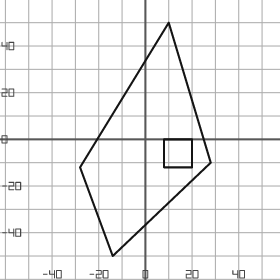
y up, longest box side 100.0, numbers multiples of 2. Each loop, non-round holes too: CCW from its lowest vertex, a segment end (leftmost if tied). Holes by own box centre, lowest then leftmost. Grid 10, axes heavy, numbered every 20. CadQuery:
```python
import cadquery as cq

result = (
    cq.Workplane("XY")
    .moveTo(-14.0, -50.0)
    .lineTo(28.0, -10.0)
    .lineTo(10.0, 50.0)
    .lineTo(-28.0, -12.0)
    .close()
    .moveTo(8.0, -12.0)
    .lineTo(20.0, -12.0)
    .lineTo(20.0, 0.0)
    .lineTo(8.0, 0.0)
    .close()
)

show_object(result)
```